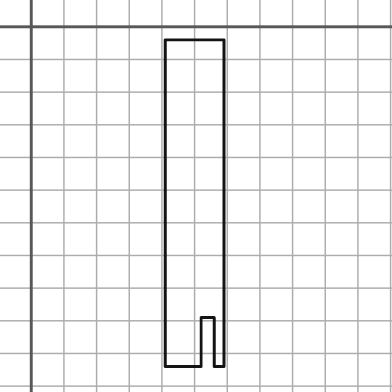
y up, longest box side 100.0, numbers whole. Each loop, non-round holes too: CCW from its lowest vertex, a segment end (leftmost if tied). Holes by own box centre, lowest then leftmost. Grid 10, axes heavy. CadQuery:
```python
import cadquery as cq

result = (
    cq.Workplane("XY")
    .moveTo(41.0, -104.0)
    .lineTo(52.0, -104.0)
    .lineTo(52.0, -89.0)
    .lineTo(56.0, -89.0)
    .lineTo(56.0, -104.0)
    .lineTo(59.0, -104.0)
    .lineTo(59.0, -4.0)
    .lineTo(41.0, -4.0)
    .close()
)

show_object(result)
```